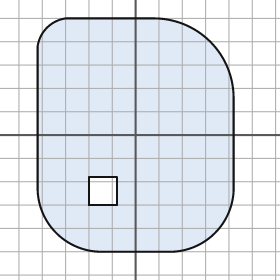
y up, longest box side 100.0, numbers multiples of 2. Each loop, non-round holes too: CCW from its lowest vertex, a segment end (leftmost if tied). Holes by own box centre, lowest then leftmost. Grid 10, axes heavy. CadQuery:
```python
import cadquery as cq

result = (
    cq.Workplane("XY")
    .moveTo(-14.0, -50.0)
    .lineTo(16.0, -50.0)
    .threePointArc((34.0, -42.0), (42.0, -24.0))
    .lineTo(42.0, 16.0)
    .threePointArc((32.0, 40.0), (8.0, 50.0))
    .lineTo(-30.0, 50.0)
    .threePointArc((-38.0, 46.0), (-42.0, 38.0))
    .lineTo(-42.0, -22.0)
    .threePointArc((-34.0, -42.0), (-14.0, -50.0))
    .close()
    .moveTo(-20.0, -30.0)
    .lineTo(-8.0, -30.0)
    .lineTo(-8.0, -18.0)
    .lineTo(-20.0, -18.0)
    .close()
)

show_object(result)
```